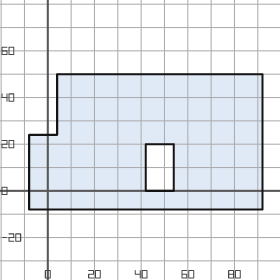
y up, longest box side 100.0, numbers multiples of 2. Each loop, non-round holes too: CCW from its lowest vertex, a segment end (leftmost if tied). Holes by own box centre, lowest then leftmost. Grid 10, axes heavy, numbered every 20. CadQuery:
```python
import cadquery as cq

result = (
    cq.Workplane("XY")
    .moveTo(-8.0, -8.0)
    .lineTo(92.0, -8.0)
    .lineTo(92.0, 50.0)
    .lineTo(4.0, 50.0)
    .lineTo(4.0, 24.0)
    .lineTo(-8.0, 24.0)
    .close()
    .moveTo(42.0, 0.0)
    .lineTo(54.0, 0.0)
    .lineTo(54.0, 20.0)
    .lineTo(42.0, 20.0)
    .close()
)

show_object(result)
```